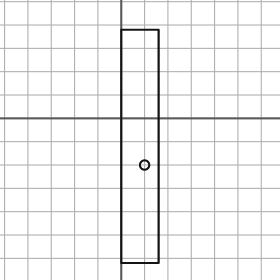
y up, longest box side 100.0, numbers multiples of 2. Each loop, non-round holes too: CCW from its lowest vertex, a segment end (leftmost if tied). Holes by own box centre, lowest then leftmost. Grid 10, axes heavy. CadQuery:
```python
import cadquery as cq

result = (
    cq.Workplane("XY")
    .moveTo(0.0, -62.0)
    .lineTo(16.0, -62.0)
    .lineTo(16.0, 38.0)
    .lineTo(0.0, 38.0)
    .close()
    .moveTo(10.0, -20.0)
    .circle(2.0)
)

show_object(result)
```